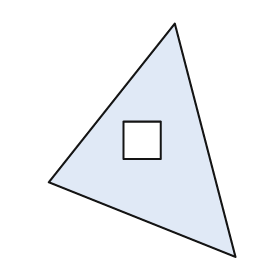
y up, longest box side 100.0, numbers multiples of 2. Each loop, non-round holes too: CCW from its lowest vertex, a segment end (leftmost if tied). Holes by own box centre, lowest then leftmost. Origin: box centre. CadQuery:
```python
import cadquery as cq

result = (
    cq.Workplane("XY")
    .moveTo(40.0, -50.0)
    .lineTo(14.0, 50.0)
    .lineTo(-40.0, -18.0)
    .close()
    .moveTo(-8.0, -8.0)
    .lineTo(8.0, -8.0)
    .lineTo(8.0, 8.0)
    .lineTo(-8.0, 8.0)
    .close()
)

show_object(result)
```